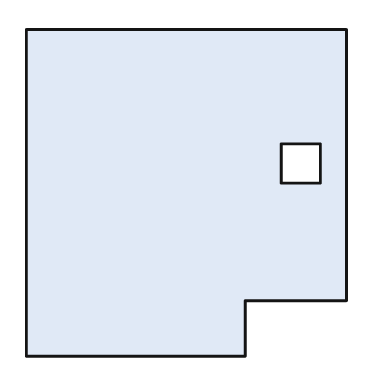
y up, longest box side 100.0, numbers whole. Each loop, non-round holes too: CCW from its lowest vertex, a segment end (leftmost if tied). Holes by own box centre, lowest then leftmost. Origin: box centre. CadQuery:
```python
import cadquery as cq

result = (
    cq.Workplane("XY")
    .moveTo(-49.0, -50.0)
    .lineTo(18.0, -50.0)
    .lineTo(18.0, -33.0)
    .lineTo(49.0, -33.0)
    .lineTo(49.0, 50.0)
    .lineTo(-49.0, 50.0)
    .close()
    .moveTo(29.0, 3.0)
    .lineTo(41.0, 3.0)
    .lineTo(41.0, 15.0)
    .lineTo(29.0, 15.0)
    .close()
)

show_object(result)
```